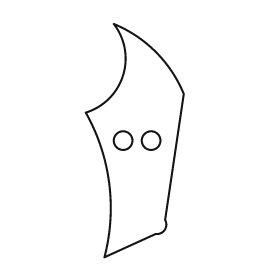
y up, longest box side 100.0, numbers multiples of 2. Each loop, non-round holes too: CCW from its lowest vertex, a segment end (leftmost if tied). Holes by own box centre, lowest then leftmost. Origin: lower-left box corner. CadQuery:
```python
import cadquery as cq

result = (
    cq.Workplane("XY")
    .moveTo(8.0, 0.0)
    .lineTo(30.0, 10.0)
    .threePointArc((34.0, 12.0), (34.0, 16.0))
    .lineTo(42.0, 70.0)
    .threePointArc((30.0, 88.0), (12.0, 100.0))
    .threePointArc((16.0, 78.0), (0.0, 62.0))
    .threePointArc((10.0, 32.0), (8.0, 0.0))
    .close()
    .moveTo(16.0, 50.0)
    .circle(4.0)
    .moveTo(28.0, 50.0)
    .circle(4.0)
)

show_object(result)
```